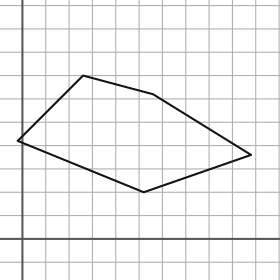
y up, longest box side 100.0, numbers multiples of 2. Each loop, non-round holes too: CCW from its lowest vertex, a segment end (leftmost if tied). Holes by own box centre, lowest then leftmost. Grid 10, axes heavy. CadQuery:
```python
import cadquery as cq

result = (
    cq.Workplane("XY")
    .moveTo(52.0, 20.0)
    .lineTo(98.0, 36.0)
    .lineTo(56.0, 62.0)
    .lineTo(26.0, 70.0)
    .lineTo(-2.0, 42.0)
    .close()
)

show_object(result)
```